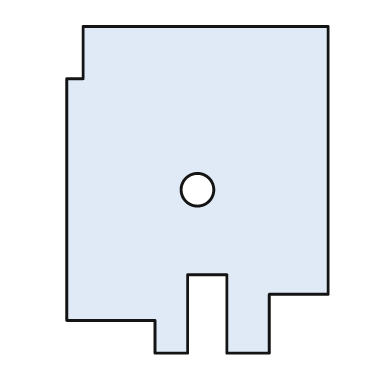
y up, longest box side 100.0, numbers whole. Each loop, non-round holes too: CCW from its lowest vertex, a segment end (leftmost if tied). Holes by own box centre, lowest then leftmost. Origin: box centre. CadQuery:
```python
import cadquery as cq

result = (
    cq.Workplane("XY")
    .moveTo(-13.0, -50.0)
    .lineTo(-3.0, -50.0)
    .lineTo(-3.0, -26.0)
    .lineTo(9.0, -26.0)
    .lineTo(9.0, -50.0)
    .lineTo(22.0, -50.0)
    .lineTo(22.0, -32.0)
    .lineTo(40.0, -32.0)
    .lineTo(40.0, 50.0)
    .lineTo(-35.0, 50.0)
    .lineTo(-35.0, 34.0)
    .lineTo(-40.0, 34.0)
    .lineTo(-40.0, -40.0)
    .lineTo(-13.0, -40.0)
    .close()
    .moveTo(0.0, 0.0)
    .circle(5.0)
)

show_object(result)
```